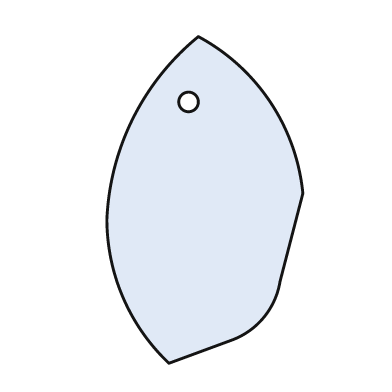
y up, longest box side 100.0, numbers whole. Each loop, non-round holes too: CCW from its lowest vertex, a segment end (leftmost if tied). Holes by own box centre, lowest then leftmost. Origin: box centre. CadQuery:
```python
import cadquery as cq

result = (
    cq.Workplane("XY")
    .moveTo(-11.0, -50.0)
    .lineTo(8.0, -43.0)
    .threePointArc((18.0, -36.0), (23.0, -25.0))
    .lineTo(30.0, 2.0)
    .threePointArc((20.0, 30.0), (-2.0, 50.0))
    .threePointArc((-22.0, 25.0), (-30.0, -6.0))
    .threePointArc((-25.0, -30.0), (-11.0, -50.0))
    .close()
    .moveTo(-5.0, 30.0)
    .circle(3.0)
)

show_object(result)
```